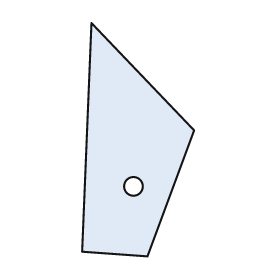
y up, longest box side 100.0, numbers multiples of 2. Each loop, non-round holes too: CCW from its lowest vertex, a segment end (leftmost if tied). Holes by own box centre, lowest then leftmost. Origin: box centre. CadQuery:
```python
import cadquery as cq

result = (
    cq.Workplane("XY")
    .moveTo(4.0, -50.0)
    .lineTo(24.0, 4.0)
    .lineTo(-20.0, 50.0)
    .lineTo(-24.0, -48.0)
    .close()
    .moveTo(-2.0, -20.0)
    .circle(4.0)
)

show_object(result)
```